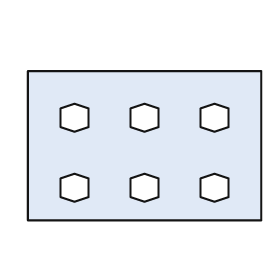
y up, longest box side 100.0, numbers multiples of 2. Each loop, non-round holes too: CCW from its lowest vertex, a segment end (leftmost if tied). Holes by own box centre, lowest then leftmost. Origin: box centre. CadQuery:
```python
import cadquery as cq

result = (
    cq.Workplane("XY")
    .moveTo(-50.0, -32.0)
    .lineTo(50.0, -32.0)
    .lineTo(50.0, 32.0)
    .lineTo(-50.0, 32.0)
    .close()
    .moveTo(-30.0, -24.0)
    .lineTo(-24.0, -22.0)
    .lineTo(-24.0, -14.0)
    .lineTo(-30.0, -12.0)
    .lineTo(-36.0, -14.0)
    .lineTo(-36.0, -22.0)
    .close()
    .moveTo(0.0, -24.0)
    .lineTo(6.0, -22.0)
    .lineTo(6.0, -14.0)
    .lineTo(0.0, -12.0)
    .lineTo(-6.0, -14.0)
    .lineTo(-6.0, -22.0)
    .close()
    .moveTo(30.0, -24.0)
    .lineTo(36.0, -22.0)
    .lineTo(36.0, -14.0)
    .lineTo(30.0, -12.0)
    .lineTo(24.0, -14.0)
    .lineTo(24.0, -22.0)
    .close()
    .moveTo(-30.0, 6.0)
    .lineTo(-24.0, 8.0)
    .lineTo(-24.0, 16.0)
    .lineTo(-30.0, 18.0)
    .lineTo(-36.0, 16.0)
    .lineTo(-36.0, 8.0)
    .close()
    .moveTo(0.0, 6.0)
    .lineTo(6.0, 8.0)
    .lineTo(6.0, 16.0)
    .lineTo(0.0, 18.0)
    .lineTo(-6.0, 16.0)
    .lineTo(-6.0, 8.0)
    .close()
    .moveTo(30.0, 6.0)
    .lineTo(36.0, 8.0)
    .lineTo(36.0, 16.0)
    .lineTo(30.0, 18.0)
    .lineTo(24.0, 16.0)
    .lineTo(24.0, 8.0)
    .close()
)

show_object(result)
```